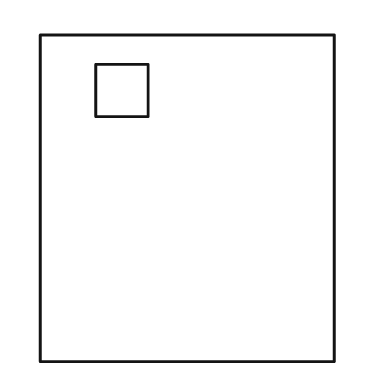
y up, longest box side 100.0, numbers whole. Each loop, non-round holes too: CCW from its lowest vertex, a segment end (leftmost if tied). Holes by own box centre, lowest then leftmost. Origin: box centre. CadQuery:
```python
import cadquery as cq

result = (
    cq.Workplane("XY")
    .moveTo(-45.0, -50.0)
    .lineTo(45.0, -50.0)
    .lineTo(45.0, 50.0)
    .lineTo(-45.0, 50.0)
    .close()
    .moveTo(-28.0, 25.0)
    .lineTo(-12.0, 25.0)
    .lineTo(-12.0, 41.0)
    .lineTo(-28.0, 41.0)
    .close()
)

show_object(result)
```